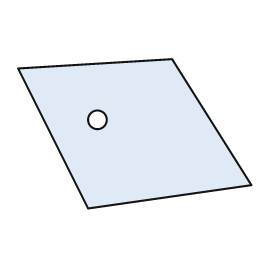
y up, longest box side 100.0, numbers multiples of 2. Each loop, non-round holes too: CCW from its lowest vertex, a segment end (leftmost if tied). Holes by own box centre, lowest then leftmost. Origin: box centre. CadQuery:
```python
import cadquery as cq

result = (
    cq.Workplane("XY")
    .moveTo(-20.0, -32.0)
    .lineTo(50.0, -22.0)
    .lineTo(16.0, 32.0)
    .lineTo(-50.0, 28.0)
    .close()
    .moveTo(-16.0, 6.0)
    .circle(4.0)
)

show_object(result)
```